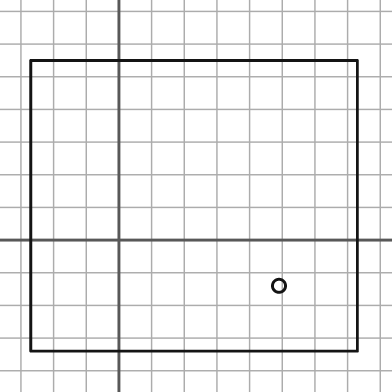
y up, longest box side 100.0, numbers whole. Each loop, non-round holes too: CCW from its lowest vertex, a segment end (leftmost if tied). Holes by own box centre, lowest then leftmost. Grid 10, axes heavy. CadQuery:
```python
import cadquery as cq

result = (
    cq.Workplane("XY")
    .moveTo(-27.0, -34.0)
    .lineTo(73.0, -34.0)
    .lineTo(73.0, 55.0)
    .lineTo(-27.0, 55.0)
    .close()
    .moveTo(49.0, -14.0)
    .circle(2.0)
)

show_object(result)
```